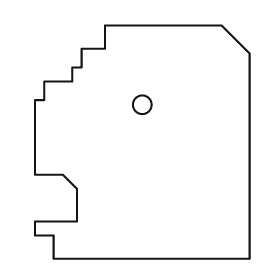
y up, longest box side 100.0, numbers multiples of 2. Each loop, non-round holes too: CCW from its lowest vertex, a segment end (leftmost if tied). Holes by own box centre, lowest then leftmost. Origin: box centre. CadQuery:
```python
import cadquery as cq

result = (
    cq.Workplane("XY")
    .moveTo(-38.0, -50.0)
    .lineTo(46.0, -50.0)
    .lineTo(46.0, 38.0)
    .lineTo(34.0, 50.0)
    .lineTo(-16.0, 50.0)
    .lineTo(-16.0, 40.0)
    .lineTo(-26.0, 40.0)
    .lineTo(-26.0, 32.0)
    .lineTo(-30.0, 32.0)
    .lineTo(-30.0, 26.0)
    .lineTo(-42.0, 26.0)
    .lineTo(-42.0, 18.0)
    .lineTo(-46.0, 18.0)
    .lineTo(-46.0, -14.0)
    .lineTo(-34.0, -14.0)
    .lineTo(-28.0, -20.0)
    .lineTo(-28.0, -34.0)
    .lineTo(-46.0, -34.0)
    .lineTo(-46.0, -40.0)
    .lineTo(-38.0, -40.0)
    .close()
    .moveTo(0.0, 16.0)
    .circle(4.0)
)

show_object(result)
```